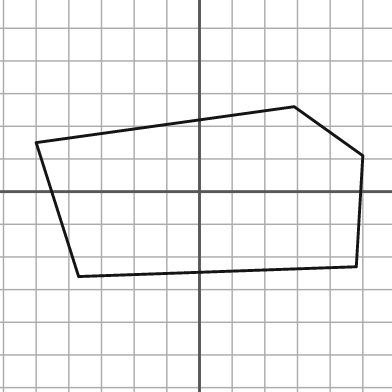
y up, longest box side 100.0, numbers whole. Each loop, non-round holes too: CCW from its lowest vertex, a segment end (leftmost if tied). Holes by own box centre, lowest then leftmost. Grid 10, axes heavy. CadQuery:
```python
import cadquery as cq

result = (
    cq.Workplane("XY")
    .moveTo(-37.0, -26.0)
    .lineTo(48.0, -23.0)
    .lineTo(50.0, 11.0)
    .lineTo(29.0, 26.0)
    .lineTo(-50.0, 15.0)
    .close()
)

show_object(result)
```